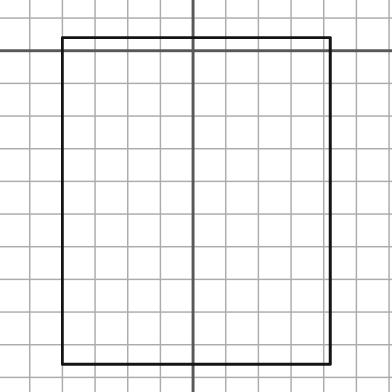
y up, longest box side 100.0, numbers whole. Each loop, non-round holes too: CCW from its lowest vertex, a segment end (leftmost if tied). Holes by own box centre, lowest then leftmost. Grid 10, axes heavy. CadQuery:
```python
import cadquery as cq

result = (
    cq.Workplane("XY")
    .moveTo(-40.0, -96.0)
    .lineTo(42.0, -96.0)
    .lineTo(42.0, 4.0)
    .lineTo(-40.0, 4.0)
    .close()
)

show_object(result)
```